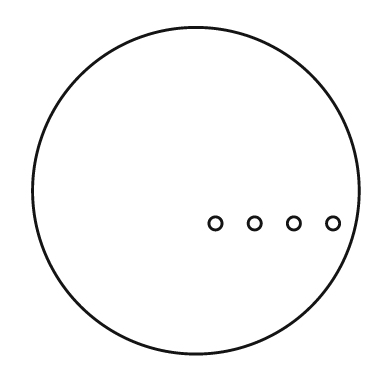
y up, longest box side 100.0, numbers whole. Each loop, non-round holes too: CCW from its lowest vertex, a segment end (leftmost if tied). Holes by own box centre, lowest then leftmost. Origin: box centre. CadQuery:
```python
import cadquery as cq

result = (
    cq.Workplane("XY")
    .moveTo(0.0, 0.0)
    .circle(50.0)
    .moveTo(6.0, -10.0)
    .circle(2.0)
    .moveTo(18.0, -10.0)
    .circle(2.0)
    .moveTo(30.0, -10.0)
    .circle(2.0)
    .moveTo(42.0, -10.0)
    .circle(2.0)
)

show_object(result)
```